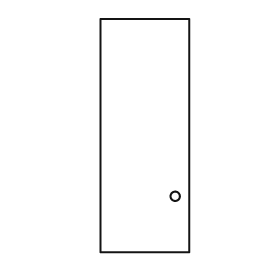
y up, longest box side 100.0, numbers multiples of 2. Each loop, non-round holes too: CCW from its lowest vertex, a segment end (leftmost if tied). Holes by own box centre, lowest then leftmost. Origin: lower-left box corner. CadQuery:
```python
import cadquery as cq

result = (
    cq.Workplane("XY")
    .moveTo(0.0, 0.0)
    .lineTo(38.0, 0.0)
    .lineTo(38.0, 100.0)
    .lineTo(0.0, 100.0)
    .close()
    .moveTo(32.0, 24.0)
    .circle(2.0)
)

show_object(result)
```